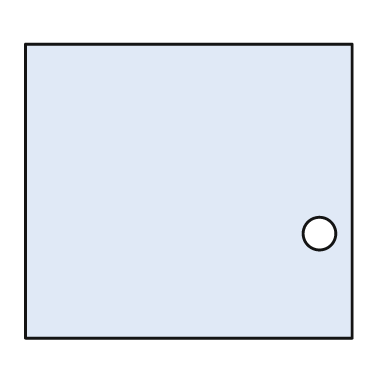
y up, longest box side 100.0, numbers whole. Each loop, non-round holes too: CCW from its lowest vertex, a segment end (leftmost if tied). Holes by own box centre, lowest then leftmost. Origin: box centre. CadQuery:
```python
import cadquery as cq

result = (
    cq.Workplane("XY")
    .moveTo(-50.0, -45.0)
    .lineTo(50.0, -45.0)
    .lineTo(50.0, 45.0)
    .lineTo(-50.0, 45.0)
    .close()
    .moveTo(40.0, -13.0)
    .circle(5.0)
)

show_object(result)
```